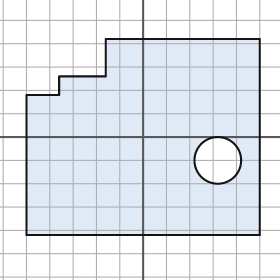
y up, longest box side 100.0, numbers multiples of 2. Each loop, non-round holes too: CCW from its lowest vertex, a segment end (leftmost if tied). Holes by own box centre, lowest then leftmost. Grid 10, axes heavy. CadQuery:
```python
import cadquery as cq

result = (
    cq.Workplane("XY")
    .moveTo(-50.0, -42.0)
    .lineTo(50.0, -42.0)
    .lineTo(50.0, 42.0)
    .lineTo(-16.0, 42.0)
    .lineTo(-16.0, 26.0)
    .lineTo(-36.0, 26.0)
    .lineTo(-36.0, 18.0)
    .lineTo(-50.0, 18.0)
    .close()
    .moveTo(32.0, -10.0)
    .circle(10.0)
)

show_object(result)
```